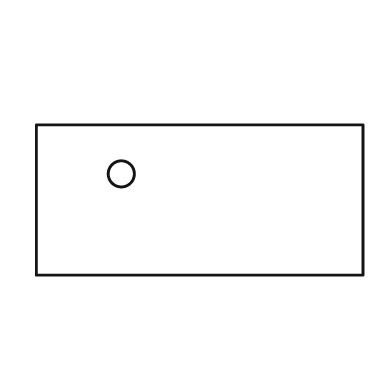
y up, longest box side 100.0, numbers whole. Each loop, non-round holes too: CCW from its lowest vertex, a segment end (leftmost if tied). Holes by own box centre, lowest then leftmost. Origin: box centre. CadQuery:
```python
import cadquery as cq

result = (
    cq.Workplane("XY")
    .moveTo(-50.0, -23.0)
    .lineTo(50.0, -23.0)
    .lineTo(50.0, 23.0)
    .lineTo(-50.0, 23.0)
    .close()
    .moveTo(-24.0, 8.0)
    .circle(4.0)
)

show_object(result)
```